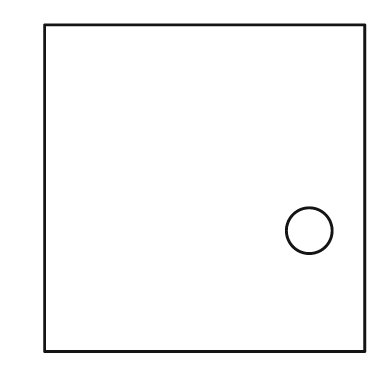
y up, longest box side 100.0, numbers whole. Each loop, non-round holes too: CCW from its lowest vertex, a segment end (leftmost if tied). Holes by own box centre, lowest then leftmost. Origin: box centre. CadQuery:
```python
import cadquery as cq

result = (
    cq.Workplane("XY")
    .moveTo(-49.0, -50.0)
    .lineTo(49.0, -50.0)
    .lineTo(49.0, 50.0)
    .lineTo(-49.0, 50.0)
    .close()
    .moveTo(32.0, -13.0)
    .circle(7.0)
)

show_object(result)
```